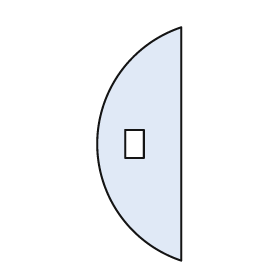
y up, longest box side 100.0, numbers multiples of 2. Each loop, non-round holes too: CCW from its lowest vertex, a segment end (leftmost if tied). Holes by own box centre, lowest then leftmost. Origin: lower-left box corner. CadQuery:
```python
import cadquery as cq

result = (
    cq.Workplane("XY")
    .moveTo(36.0, 0.0)
    .lineTo(36.0, 100.0)
    .threePointArc((0.0, 50.0), (36.0, 0.0))
    .close()
    .moveTo(12.0, 44.0)
    .lineTo(20.0, 44.0)
    .lineTo(20.0, 56.0)
    .lineTo(12.0, 56.0)
    .close()
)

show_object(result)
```